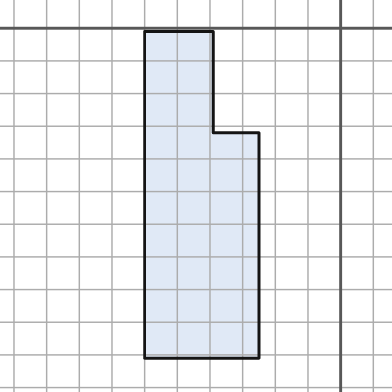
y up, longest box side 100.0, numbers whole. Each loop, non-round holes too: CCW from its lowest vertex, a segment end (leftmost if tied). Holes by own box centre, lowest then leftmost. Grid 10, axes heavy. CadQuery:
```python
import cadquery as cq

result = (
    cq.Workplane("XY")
    .moveTo(-60.0, -101.0)
    .lineTo(-25.0, -101.0)
    .lineTo(-25.0, -32.0)
    .lineTo(-39.0, -32.0)
    .lineTo(-39.0, -1.0)
    .lineTo(-60.0, -1.0)
    .close()
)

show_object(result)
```